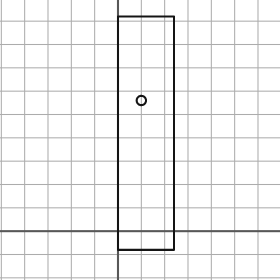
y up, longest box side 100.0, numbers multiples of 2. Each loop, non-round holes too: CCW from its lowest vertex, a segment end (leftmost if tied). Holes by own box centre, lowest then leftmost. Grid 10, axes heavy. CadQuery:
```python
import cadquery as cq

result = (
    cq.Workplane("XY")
    .moveTo(0.0, -8.0)
    .lineTo(24.0, -8.0)
    .lineTo(24.0, 92.0)
    .lineTo(0.0, 92.0)
    .close()
    .moveTo(10.0, 56.0)
    .circle(2.0)
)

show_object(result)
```